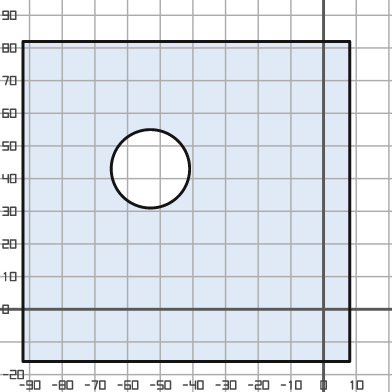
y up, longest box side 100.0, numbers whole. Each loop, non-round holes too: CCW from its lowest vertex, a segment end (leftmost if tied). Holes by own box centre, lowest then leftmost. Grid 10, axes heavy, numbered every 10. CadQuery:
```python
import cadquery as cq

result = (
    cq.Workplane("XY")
    .moveTo(-92.0, -16.0)
    .lineTo(8.0, -16.0)
    .lineTo(8.0, 82.0)
    .lineTo(-92.0, 82.0)
    .close()
    .moveTo(-53.0, 43.0)
    .circle(12.0)
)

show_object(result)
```